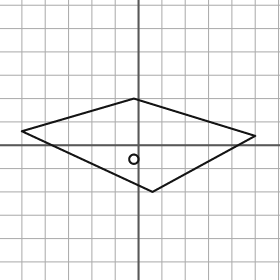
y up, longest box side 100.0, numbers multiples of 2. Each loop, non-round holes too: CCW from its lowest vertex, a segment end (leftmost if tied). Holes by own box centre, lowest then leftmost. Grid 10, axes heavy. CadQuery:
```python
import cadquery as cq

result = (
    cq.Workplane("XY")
    .moveTo(6.0, -20.0)
    .lineTo(50.0, 4.0)
    .lineTo(-2.0, 20.0)
    .lineTo(-50.0, 6.0)
    .close()
    .moveTo(-2.0, -6.0)
    .circle(2.0)
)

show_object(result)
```